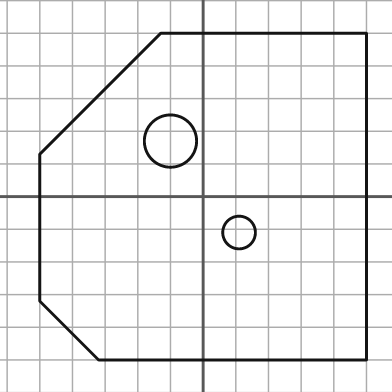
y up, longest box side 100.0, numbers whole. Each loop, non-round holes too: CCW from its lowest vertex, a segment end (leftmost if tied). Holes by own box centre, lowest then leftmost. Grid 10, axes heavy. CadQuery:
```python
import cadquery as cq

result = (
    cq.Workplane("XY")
    .moveTo(-32.0, -50.0)
    .lineTo(50.0, -50.0)
    .lineTo(50.0, 50.0)
    .lineTo(-13.0, 50.0)
    .lineTo(-50.0, 13.0)
    .lineTo(-50.0, -32.0)
    .close()
    .moveTo(11.0, -11.0)
    .circle(5.0)
    .moveTo(-10.0, 17.0)
    .circle(8.0)
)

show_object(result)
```